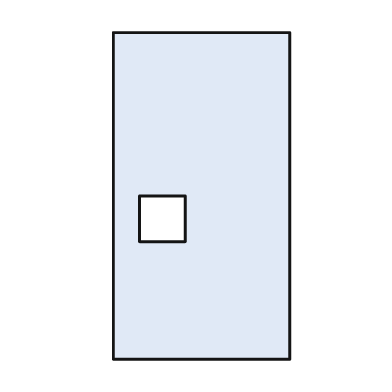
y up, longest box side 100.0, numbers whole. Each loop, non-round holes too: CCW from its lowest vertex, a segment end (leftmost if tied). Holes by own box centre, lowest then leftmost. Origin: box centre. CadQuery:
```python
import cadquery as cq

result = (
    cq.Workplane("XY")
    .moveTo(-27.0, -50.0)
    .lineTo(27.0, -50.0)
    .lineTo(27.0, 50.0)
    .lineTo(-27.0, 50.0)
    .close()
    .moveTo(-19.0, -14.0)
    .lineTo(-5.0, -14.0)
    .lineTo(-5.0, 0.0)
    .lineTo(-19.0, 0.0)
    .close()
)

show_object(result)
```